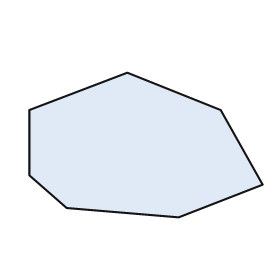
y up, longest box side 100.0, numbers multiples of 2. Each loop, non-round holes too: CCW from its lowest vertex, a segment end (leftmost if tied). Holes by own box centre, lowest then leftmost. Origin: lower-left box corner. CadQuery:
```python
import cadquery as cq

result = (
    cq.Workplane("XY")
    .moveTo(64.0, 0.0)
    .lineTo(100.0, 14.0)
    .lineTo(82.0, 46.0)
    .lineTo(42.0, 62.0)
    .lineTo(0.0, 46.0)
    .lineTo(0.0, 18.0)
    .lineTo(16.0, 4.0)
    .close()
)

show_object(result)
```